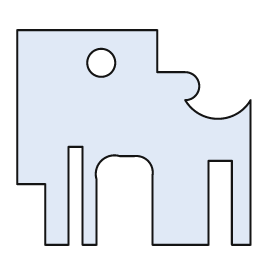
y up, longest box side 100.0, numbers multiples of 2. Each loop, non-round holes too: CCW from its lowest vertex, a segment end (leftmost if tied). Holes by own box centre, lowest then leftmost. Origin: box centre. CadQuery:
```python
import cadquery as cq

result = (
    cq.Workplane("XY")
    .moveTo(-38.0, -46.0)
    .lineTo(-28.0, -46.0)
    .lineTo(-28.0, -4.0)
    .lineTo(-22.0, -4.0)
    .lineTo(-22.0, -46.0)
    .lineTo(-16.0, -46.0)
    .lineTo(-16.0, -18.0)
    .threePointArc((-14.0, -10.0), (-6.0, -8.0))
    .lineTo(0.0, -8.0)
    .threePointArc((6.0, -10.0), (8.0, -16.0))
    .lineTo(8.0, -46.0)
    .lineTo(32.0, -46.0)
    .lineTo(32.0, -10.0)
    .lineTo(42.0, -10.0)
    .lineTo(42.0, -46.0)
    .lineTo(50.0, -46.0)
    .lineTo(50.0, 16.0)
    .threePointArc((36.0, 8.0), (22.0, 16.0))
    .threePointArc((28.0, 22.0), (22.0, 28.0))
    .lineTo(10.0, 28.0)
    .lineTo(10.0, 46.0)
    .lineTo(-50.0, 46.0)
    .lineTo(-50.0, -20.0)
    .lineTo(-38.0, -20.0)
    .close()
    .moveTo(-14.0, 32.0)
    .circle(6.0)
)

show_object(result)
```